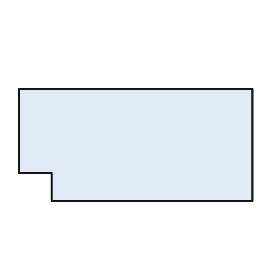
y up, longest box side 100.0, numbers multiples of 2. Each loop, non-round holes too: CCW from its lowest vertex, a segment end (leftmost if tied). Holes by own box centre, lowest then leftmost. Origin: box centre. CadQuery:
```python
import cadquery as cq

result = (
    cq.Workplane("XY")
    .moveTo(-36.0, -24.0)
    .lineTo(50.0, -24.0)
    .lineTo(50.0, 24.0)
    .lineTo(-50.0, 24.0)
    .lineTo(-50.0, -12.0)
    .lineTo(-36.0, -12.0)
    .close()
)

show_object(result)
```